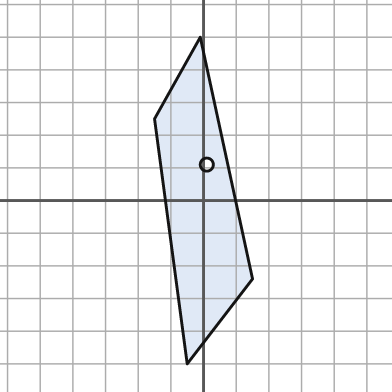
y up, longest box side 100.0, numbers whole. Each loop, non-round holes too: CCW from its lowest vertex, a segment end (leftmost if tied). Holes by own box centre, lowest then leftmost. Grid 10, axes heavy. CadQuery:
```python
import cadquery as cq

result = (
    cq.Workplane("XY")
    .moveTo(-5.0, -50.0)
    .lineTo(15.0, -24.0)
    .lineTo(-1.0, 50.0)
    .lineTo(-15.0, 25.0)
    .close()
    .moveTo(1.0, 11.0)
    .circle(2.0)
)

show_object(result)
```